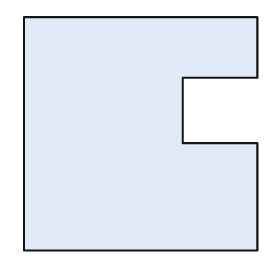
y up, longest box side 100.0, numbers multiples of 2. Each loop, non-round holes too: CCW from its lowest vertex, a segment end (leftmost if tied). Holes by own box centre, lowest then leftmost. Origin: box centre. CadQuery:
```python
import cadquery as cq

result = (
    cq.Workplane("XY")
    .moveTo(-50.0, -50.0)
    .lineTo(50.0, -50.0)
    .lineTo(50.0, -4.0)
    .lineTo(18.0, -4.0)
    .lineTo(18.0, 24.0)
    .lineTo(50.0, 24.0)
    .lineTo(50.0, 50.0)
    .lineTo(-50.0, 50.0)
    .close()
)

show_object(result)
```